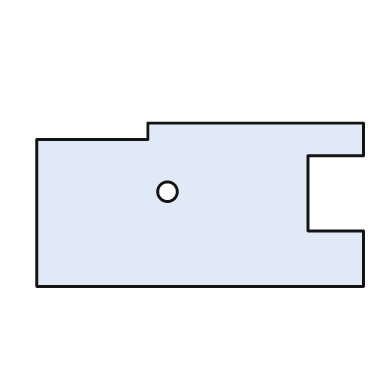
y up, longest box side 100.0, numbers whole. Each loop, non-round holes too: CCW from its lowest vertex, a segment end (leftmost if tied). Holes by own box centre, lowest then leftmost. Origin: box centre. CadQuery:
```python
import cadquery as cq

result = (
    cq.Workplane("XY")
    .moveTo(-50.0, -25.0)
    .lineTo(50.0, -25.0)
    .lineTo(50.0, -8.0)
    .lineTo(33.0, -8.0)
    .lineTo(33.0, 15.0)
    .lineTo(50.0, 15.0)
    .lineTo(50.0, 25.0)
    .lineTo(-16.0, 25.0)
    .lineTo(-16.0, 20.0)
    .lineTo(-50.0, 20.0)
    .close()
    .moveTo(-10.0, 4.0)
    .circle(3.0)
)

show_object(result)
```